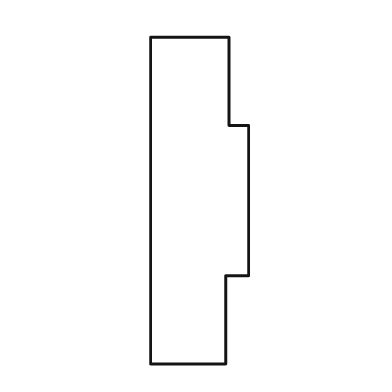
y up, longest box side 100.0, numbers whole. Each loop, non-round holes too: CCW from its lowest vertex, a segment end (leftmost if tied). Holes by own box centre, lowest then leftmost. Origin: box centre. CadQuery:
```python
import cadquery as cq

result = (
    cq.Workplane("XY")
    .moveTo(-15.0, -50.0)
    .lineTo(8.0, -50.0)
    .lineTo(8.0, -23.0)
    .lineTo(15.0, -23.0)
    .lineTo(15.0, 23.0)
    .lineTo(9.0, 23.0)
    .lineTo(9.0, 50.0)
    .lineTo(-15.0, 50.0)
    .close()
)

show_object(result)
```